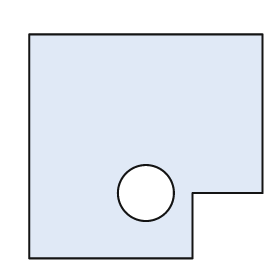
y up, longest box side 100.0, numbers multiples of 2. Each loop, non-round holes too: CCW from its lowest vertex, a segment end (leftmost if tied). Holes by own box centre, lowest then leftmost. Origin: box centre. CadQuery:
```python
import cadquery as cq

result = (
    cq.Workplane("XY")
    .moveTo(-50.0, -48.0)
    .lineTo(20.0, -48.0)
    .lineTo(20.0, -20.0)
    .lineTo(50.0, -20.0)
    .lineTo(50.0, 48.0)
    .lineTo(-50.0, 48.0)
    .close()
    .moveTo(0.0, -20.0)
    .circle(12.0)
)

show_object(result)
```